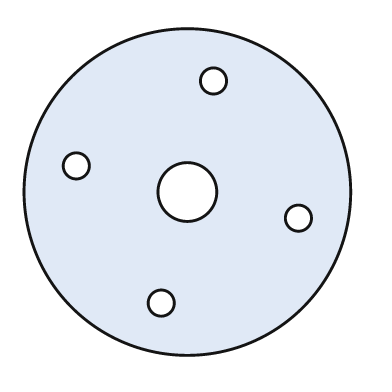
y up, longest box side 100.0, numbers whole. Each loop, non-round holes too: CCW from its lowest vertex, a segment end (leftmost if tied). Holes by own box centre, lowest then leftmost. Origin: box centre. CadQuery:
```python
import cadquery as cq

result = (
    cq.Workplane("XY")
    .moveTo(0.0, 0.0)
    .circle(50.0)
    .moveTo(-8.0, -34.0)
    .circle(4.0)
    .moveTo(34.0, -8.0)
    .circle(4.0)
    .moveTo(0.0, 0.0)
    .circle(9.0)
    .moveTo(-34.0, 8.0)
    .circle(4.0)
    .moveTo(8.0, 34.0)
    .circle(4.0)
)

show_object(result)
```